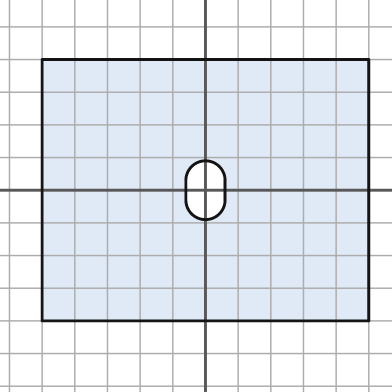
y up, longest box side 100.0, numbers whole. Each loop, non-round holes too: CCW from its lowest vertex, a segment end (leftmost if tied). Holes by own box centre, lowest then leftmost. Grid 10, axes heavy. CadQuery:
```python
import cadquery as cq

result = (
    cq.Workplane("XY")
    .moveTo(-50.0, -40.0)
    .lineTo(50.0, -40.0)
    .lineTo(50.0, 40.0)
    .lineTo(-50.0, 40.0)
    .close()
    .moveTo(-6.0, -3.0)
    .threePointArc((0.0, -9.0), (6.0, -3.0))
    .lineTo(6.0, 3.0)
    .threePointArc((0.0, 9.0), (-6.0, 3.0))
    .close()
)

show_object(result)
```